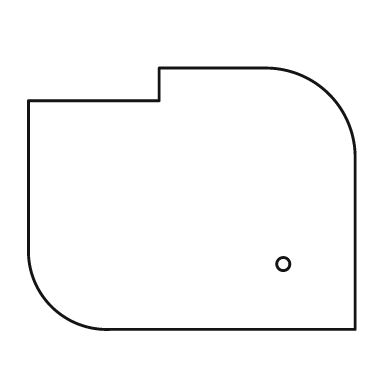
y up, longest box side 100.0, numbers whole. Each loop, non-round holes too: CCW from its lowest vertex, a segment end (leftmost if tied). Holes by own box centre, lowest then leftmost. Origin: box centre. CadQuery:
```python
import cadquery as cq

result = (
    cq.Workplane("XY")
    .moveTo(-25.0, -40.0)
    .lineTo(50.0, -40.0)
    .lineTo(50.0, 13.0)
    .threePointArc((42.0, 32.0), (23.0, 40.0))
    .lineTo(-10.0, 40.0)
    .lineTo(-10.0, 30.0)
    .lineTo(-50.0, 30.0)
    .lineTo(-50.0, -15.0)
    .threePointArc((-43.0, -33.0), (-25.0, -40.0))
    .close()
    .moveTo(28.0, -20.0)
    .circle(2.0)
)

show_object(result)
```